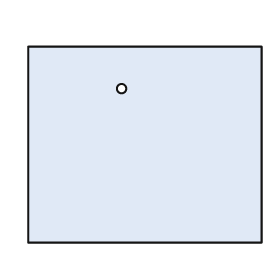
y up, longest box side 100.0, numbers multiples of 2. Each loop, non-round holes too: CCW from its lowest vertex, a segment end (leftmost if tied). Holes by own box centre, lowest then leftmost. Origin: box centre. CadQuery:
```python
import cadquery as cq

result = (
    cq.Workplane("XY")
    .moveTo(-50.0, -42.0)
    .lineTo(50.0, -42.0)
    .lineTo(50.0, 42.0)
    .lineTo(-50.0, 42.0)
    .close()
    .moveTo(-10.0, 24.0)
    .circle(2.0)
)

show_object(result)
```